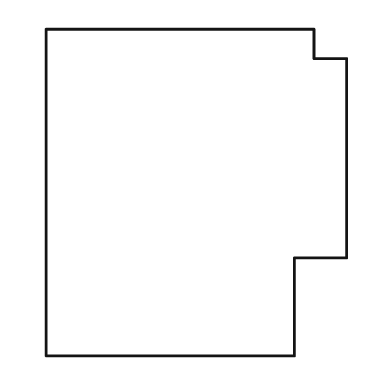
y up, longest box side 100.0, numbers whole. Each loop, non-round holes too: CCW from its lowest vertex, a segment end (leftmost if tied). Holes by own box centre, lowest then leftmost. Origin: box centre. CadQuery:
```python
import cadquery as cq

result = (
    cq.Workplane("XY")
    .moveTo(-46.0, -50.0)
    .lineTo(30.0, -50.0)
    .lineTo(30.0, -20.0)
    .lineTo(46.0, -20.0)
    .lineTo(46.0, 41.0)
    .lineTo(36.0, 41.0)
    .lineTo(36.0, 50.0)
    .lineTo(-46.0, 50.0)
    .close()
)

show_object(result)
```